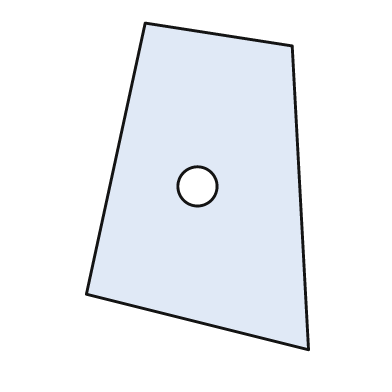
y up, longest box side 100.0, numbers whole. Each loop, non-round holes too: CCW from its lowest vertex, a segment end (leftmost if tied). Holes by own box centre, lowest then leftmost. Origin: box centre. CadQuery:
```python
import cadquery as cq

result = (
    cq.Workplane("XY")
    .moveTo(34.0, -50.0)
    .lineTo(29.0, 43.0)
    .lineTo(-16.0, 50.0)
    .lineTo(-34.0, -33.0)
    .close()
    .moveTo(0.0, 0.0)
    .circle(6.0)
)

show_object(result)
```